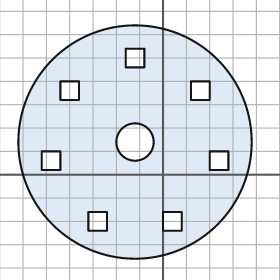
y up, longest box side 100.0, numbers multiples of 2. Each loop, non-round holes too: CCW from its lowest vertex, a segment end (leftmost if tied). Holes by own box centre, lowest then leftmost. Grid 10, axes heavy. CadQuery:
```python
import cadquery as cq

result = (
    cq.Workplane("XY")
    .moveTo(-12.0, 14.0)
    .circle(50.0)
    .moveTo(-32.0, -24.0)
    .lineTo(-24.0, -24.0)
    .lineTo(-24.0, -16.0)
    .lineTo(-32.0, -16.0)
    .close()
    .moveTo(0.0, -24.0)
    .lineTo(8.0, -24.0)
    .lineTo(8.0, -16.0)
    .lineTo(0.0, -16.0)
    .close()
    .moveTo(-52.0, 2.0)
    .lineTo(-44.0, 2.0)
    .lineTo(-44.0, 10.0)
    .lineTo(-52.0, 10.0)
    .close()
    .moveTo(20.0, 2.0)
    .lineTo(28.0, 2.0)
    .lineTo(28.0, 10.0)
    .lineTo(20.0, 10.0)
    .close()
    .moveTo(-12.0, 14.0)
    .circle(8.0)
    .moveTo(-44.0, 32.0)
    .lineTo(-36.0, 32.0)
    .lineTo(-36.0, 40.0)
    .lineTo(-44.0, 40.0)
    .close()
    .moveTo(12.0, 32.0)
    .lineTo(20.0, 32.0)
    .lineTo(20.0, 40.0)
    .lineTo(12.0, 40.0)
    .close()
    .moveTo(-16.0, 46.0)
    .lineTo(-8.0, 46.0)
    .lineTo(-8.0, 54.0)
    .lineTo(-16.0, 54.0)
    .close()
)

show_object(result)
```